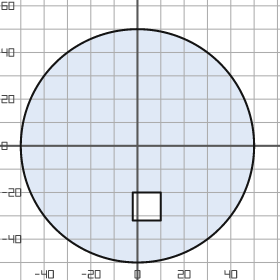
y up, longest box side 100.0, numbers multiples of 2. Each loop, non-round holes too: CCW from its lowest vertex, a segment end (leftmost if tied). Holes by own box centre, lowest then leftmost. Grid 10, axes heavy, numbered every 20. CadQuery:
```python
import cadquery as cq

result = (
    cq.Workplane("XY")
    .moveTo(0.0, 0.0)
    .circle(50.0)
    .moveTo(-2.0, -32.0)
    .lineTo(10.0, -32.0)
    .lineTo(10.0, -20.0)
    .lineTo(-2.0, -20.0)
    .close()
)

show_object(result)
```